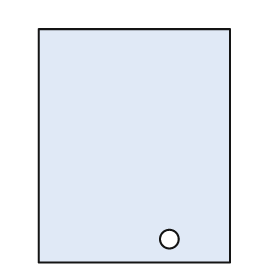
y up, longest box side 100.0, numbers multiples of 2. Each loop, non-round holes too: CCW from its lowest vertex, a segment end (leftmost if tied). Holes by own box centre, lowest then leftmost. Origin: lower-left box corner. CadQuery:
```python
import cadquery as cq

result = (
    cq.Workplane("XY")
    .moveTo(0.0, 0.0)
    .lineTo(82.0, 0.0)
    .lineTo(82.0, 100.0)
    .lineTo(0.0, 100.0)
    .close()
    .moveTo(56.0, 10.0)
    .circle(4.0)
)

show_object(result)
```